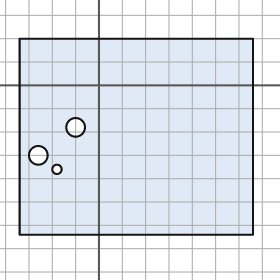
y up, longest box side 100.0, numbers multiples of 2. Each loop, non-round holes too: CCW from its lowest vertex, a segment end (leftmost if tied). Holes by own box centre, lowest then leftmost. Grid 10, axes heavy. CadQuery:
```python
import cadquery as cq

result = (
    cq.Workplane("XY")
    .moveTo(-34.0, -64.0)
    .lineTo(66.0, -64.0)
    .lineTo(66.0, 20.0)
    .lineTo(-34.0, 20.0)
    .close()
    .moveTo(-18.0, -36.0)
    .circle(2.0)
    .moveTo(-26.0, -30.0)
    .circle(4.0)
    .moveTo(-10.0, -18.0)
    .circle(4.0)
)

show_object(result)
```